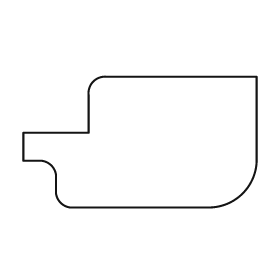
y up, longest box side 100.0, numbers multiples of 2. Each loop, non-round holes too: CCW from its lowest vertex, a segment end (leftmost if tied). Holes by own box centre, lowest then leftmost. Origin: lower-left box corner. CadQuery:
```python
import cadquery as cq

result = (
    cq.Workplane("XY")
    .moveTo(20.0, 0.0)
    .lineTo(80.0, 0.0)
    .threePointArc((94.0, 6.0), (100.0, 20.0))
    .lineTo(100.0, 56.0)
    .lineTo(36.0, 56.0)
    .threePointArc((30.0, 54.0), (28.0, 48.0))
    .lineTo(28.0, 32.0)
    .lineTo(0.0, 32.0)
    .lineTo(0.0, 20.0)
    .lineTo(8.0, 20.0)
    .threePointArc((12.0, 18.0), (14.0, 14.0))
    .lineTo(14.0, 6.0)
    .threePointArc((16.0, 2.0), (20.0, 0.0))
    .close()
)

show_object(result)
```